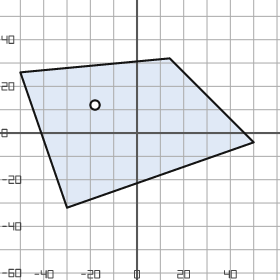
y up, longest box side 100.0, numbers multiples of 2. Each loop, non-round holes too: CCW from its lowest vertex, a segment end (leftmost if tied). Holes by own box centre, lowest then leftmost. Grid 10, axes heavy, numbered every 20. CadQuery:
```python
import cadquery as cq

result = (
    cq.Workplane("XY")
    .moveTo(-30.0, -32.0)
    .lineTo(50.0, -4.0)
    .lineTo(14.0, 32.0)
    .lineTo(-50.0, 26.0)
    .close()
    .moveTo(-18.0, 12.0)
    .circle(2.0)
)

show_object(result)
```